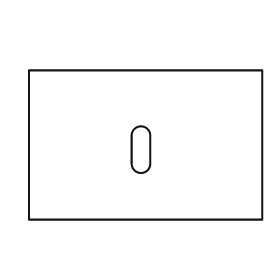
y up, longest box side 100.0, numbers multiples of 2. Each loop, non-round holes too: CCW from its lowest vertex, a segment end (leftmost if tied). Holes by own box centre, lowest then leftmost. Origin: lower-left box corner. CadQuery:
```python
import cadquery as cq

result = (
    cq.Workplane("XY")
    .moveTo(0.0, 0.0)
    .lineTo(100.0, 0.0)
    .lineTo(100.0, 64.0)
    .lineTo(0.0, 64.0)
    .close()
    .moveTo(44.0, 24.0)
    .threePointArc((48.0, 20.0), (52.0, 24.0))
    .lineTo(52.0, 36.0)
    .threePointArc((48.0, 40.0), (44.0, 36.0))
    .close()
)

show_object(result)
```